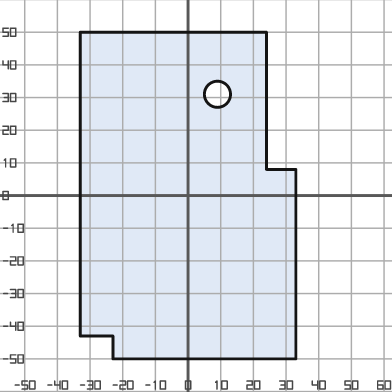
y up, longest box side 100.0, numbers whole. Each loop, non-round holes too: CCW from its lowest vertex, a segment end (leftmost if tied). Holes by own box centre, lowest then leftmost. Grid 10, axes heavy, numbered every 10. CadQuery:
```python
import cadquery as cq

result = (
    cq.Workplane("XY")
    .moveTo(-23.0, -50.0)
    .lineTo(33.0, -50.0)
    .lineTo(33.0, 8.0)
    .lineTo(24.0, 8.0)
    .lineTo(24.0, 50.0)
    .lineTo(-33.0, 50.0)
    .lineTo(-33.0, -43.0)
    .lineTo(-23.0, -43.0)
    .close()
    .moveTo(9.0, 31.0)
    .circle(4.0)
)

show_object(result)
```